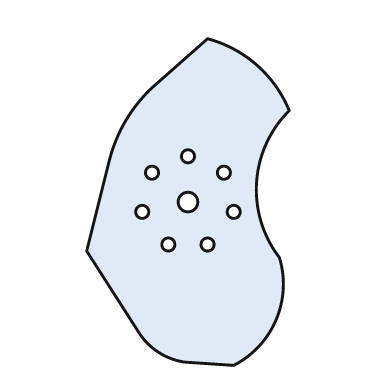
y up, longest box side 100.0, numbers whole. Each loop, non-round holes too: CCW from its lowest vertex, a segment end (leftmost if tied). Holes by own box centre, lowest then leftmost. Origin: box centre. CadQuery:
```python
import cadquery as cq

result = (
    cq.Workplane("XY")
    .moveTo(14.0, -50.0)
    .threePointArc((27.0, -36.0), (28.0, -17.0))
    .threePointArc((21.0, 6.0), (31.0, 28.0))
    .threePointArc((21.0, 42.0), (6.0, 50.0))
    .lineTo(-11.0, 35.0)
    .threePointArc((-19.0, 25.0), (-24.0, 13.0))
    .lineTo(-31.0, -15.0)
    .lineTo(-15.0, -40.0)
    .threePointArc((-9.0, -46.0), (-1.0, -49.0))
    .close()
    .moveTo(-6.0, -13.0)
    .circle(2.0)
    .moveTo(6.0, -13.0)
    .circle(2.0)
    .moveTo(-14.0, -3.0)
    .circle(2.0)
    .moveTo(14.0, -3.0)
    .circle(2.0)
    .moveTo(0.0, 0.0)
    .circle(3.0)
    .moveTo(-11.0, 9.0)
    .circle(2.0)
    .moveTo(11.0, 9.0)
    .circle(2.0)
    .moveTo(0.0, 14.0)
    .circle(2.0)
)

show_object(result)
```